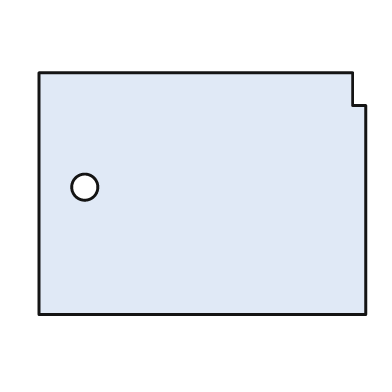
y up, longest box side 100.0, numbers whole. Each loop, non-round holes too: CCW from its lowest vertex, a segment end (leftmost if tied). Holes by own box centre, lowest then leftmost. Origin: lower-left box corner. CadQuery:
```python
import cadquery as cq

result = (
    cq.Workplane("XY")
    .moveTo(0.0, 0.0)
    .lineTo(100.0, 0.0)
    .lineTo(100.0, 64.0)
    .lineTo(96.0, 64.0)
    .lineTo(96.0, 74.0)
    .lineTo(0.0, 74.0)
    .close()
    .moveTo(14.0, 39.0)
    .circle(4.0)
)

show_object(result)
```